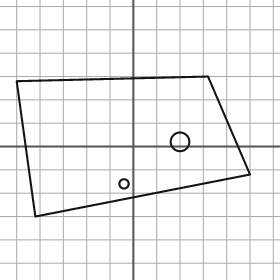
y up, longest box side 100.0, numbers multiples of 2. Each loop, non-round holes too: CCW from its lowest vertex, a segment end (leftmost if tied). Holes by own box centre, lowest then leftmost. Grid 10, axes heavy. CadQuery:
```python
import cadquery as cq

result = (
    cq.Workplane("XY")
    .moveTo(-42.0, -30.0)
    .lineTo(50.0, -12.0)
    .lineTo(32.0, 30.0)
    .lineTo(-50.0, 28.0)
    .close()
    .moveTo(-4.0, -16.0)
    .circle(2.0)
    .moveTo(20.0, 2.0)
    .circle(4.0)
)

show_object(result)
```